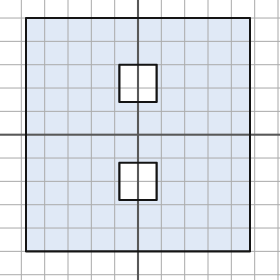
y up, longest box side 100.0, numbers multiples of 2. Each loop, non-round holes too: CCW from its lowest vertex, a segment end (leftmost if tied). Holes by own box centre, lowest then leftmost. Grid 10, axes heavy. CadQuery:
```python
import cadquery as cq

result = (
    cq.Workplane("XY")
    .moveTo(-48.0, -50.0)
    .lineTo(48.0, -50.0)
    .lineTo(48.0, 50.0)
    .lineTo(-48.0, 50.0)
    .close()
    .moveTo(-8.0, -28.0)
    .lineTo(8.0, -28.0)
    .lineTo(8.0, -12.0)
    .lineTo(-8.0, -12.0)
    .close()
    .moveTo(-8.0, 14.0)
    .lineTo(8.0, 14.0)
    .lineTo(8.0, 30.0)
    .lineTo(-8.0, 30.0)
    .close()
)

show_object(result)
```